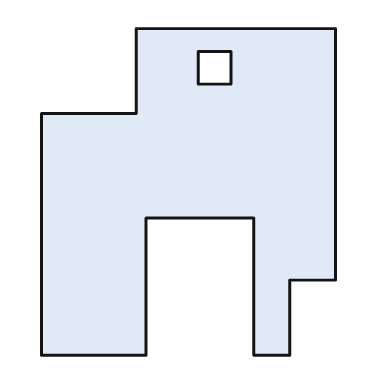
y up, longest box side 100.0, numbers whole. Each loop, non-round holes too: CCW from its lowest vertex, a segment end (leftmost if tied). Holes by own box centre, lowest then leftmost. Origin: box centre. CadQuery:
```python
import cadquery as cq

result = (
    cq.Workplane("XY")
    .moveTo(-45.0, -50.0)
    .lineTo(-13.0, -50.0)
    .lineTo(-13.0, -8.0)
    .lineTo(20.0, -8.0)
    .lineTo(20.0, -50.0)
    .lineTo(31.0, -50.0)
    .lineTo(31.0, -27.0)
    .lineTo(45.0, -27.0)
    .lineTo(45.0, 50.0)
    .lineTo(-16.0, 50.0)
    .lineTo(-16.0, 24.0)
    .lineTo(-45.0, 24.0)
    .close()
    .moveTo(3.0, 33.0)
    .lineTo(13.0, 33.0)
    .lineTo(13.0, 43.0)
    .lineTo(3.0, 43.0)
    .close()
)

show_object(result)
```